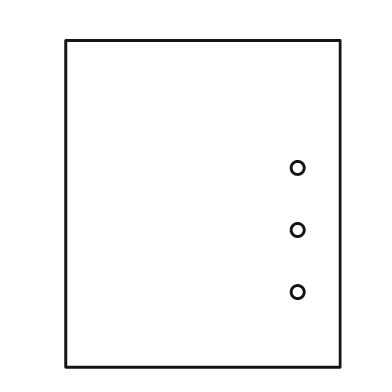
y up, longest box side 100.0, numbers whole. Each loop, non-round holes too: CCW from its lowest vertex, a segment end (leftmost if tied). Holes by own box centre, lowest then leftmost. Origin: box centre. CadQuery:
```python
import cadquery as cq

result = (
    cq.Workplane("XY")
    .moveTo(-42.0, -50.0)
    .lineTo(42.0, -50.0)
    .lineTo(42.0, 50.0)
    .lineTo(-42.0, 50.0)
    .close()
    .moveTo(29.0, -27.0)
    .circle(2.0)
    .moveTo(29.0, -8.0)
    .circle(2.0)
    .moveTo(29.0, 11.0)
    .circle(2.0)
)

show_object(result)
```